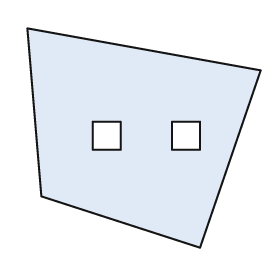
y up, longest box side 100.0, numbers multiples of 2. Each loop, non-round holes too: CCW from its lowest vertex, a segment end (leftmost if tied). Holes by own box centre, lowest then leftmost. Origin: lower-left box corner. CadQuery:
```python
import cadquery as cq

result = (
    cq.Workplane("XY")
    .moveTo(74.0, 0.0)
    .lineTo(100.0, 76.0)
    .lineTo(0.0, 94.0)
    .lineTo(6.0, 22.0)
    .close()
    .moveTo(28.0, 42.0)
    .lineTo(40.0, 42.0)
    .lineTo(40.0, 54.0)
    .lineTo(28.0, 54.0)
    .close()
    .moveTo(62.0, 42.0)
    .lineTo(74.0, 42.0)
    .lineTo(74.0, 54.0)
    .lineTo(62.0, 54.0)
    .close()
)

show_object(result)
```